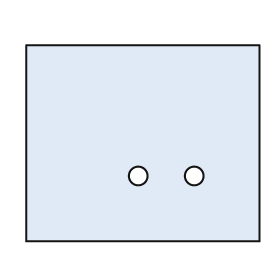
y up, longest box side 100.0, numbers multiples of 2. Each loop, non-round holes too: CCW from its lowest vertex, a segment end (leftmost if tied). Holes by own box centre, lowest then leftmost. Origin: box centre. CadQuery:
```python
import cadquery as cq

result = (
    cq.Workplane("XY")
    .moveTo(-50.0, -42.0)
    .lineTo(50.0, -42.0)
    .lineTo(50.0, 42.0)
    .lineTo(-50.0, 42.0)
    .close()
    .moveTo(-2.0, -14.0)
    .circle(4.0)
    .moveTo(22.0, -14.0)
    .circle(4.0)
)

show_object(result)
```